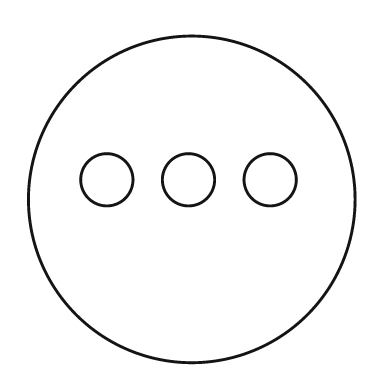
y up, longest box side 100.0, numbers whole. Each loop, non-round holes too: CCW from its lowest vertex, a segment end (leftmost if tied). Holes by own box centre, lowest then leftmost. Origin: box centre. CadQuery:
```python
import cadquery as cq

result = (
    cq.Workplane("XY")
    .moveTo(0.0, 0.0)
    .circle(50.0)
    .moveTo(-26.0, 6.0)
    .circle(8.0)
    .moveTo(-1.0, 6.0)
    .circle(8.0)
    .moveTo(24.0, 6.0)
    .circle(8.0)
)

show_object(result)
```